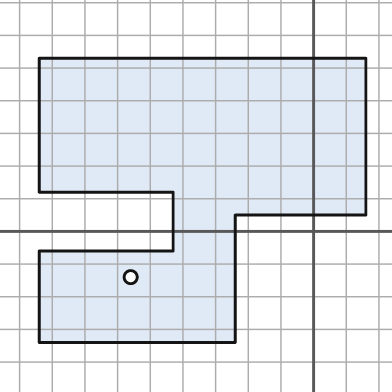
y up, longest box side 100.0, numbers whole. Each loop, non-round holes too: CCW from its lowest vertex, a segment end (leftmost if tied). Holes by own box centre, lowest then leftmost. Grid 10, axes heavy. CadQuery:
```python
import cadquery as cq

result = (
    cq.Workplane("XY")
    .moveTo(-84.0, -34.0)
    .lineTo(-24.0, -34.0)
    .lineTo(-24.0, 5.0)
    .lineTo(16.0, 5.0)
    .lineTo(16.0, 53.0)
    .lineTo(-84.0, 53.0)
    .lineTo(-84.0, 12.0)
    .lineTo(-43.0, 12.0)
    .lineTo(-43.0, -6.0)
    .lineTo(-84.0, -6.0)
    .close()
    .moveTo(-56.0, -14.0)
    .circle(2.0)
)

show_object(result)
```